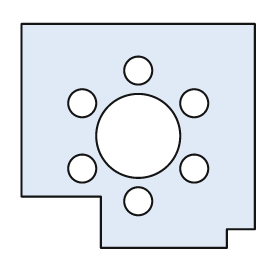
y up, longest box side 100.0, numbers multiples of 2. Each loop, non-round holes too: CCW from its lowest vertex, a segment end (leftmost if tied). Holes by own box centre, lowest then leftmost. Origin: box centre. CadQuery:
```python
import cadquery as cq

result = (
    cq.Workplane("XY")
    .moveTo(-16.0, -48.0)
    .lineTo(38.0, -48.0)
    .lineTo(38.0, -40.0)
    .lineTo(50.0, -40.0)
    .lineTo(50.0, 48.0)
    .lineTo(-50.0, 48.0)
    .lineTo(-50.0, -26.0)
    .lineTo(-16.0, -26.0)
    .close()
    .moveTo(0.0, -28.0)
    .circle(6.0)
    .moveTo(-24.0, -14.0)
    .circle(6.0)
    .moveTo(24.0, -14.0)
    .circle(6.0)
    .moveTo(0.0, 0.0)
    .circle(18.0)
    .moveTo(-24.0, 14.0)
    .circle(6.0)
    .moveTo(24.0, 14.0)
    .circle(6.0)
    .moveTo(0.0, 28.0)
    .circle(6.0)
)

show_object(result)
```